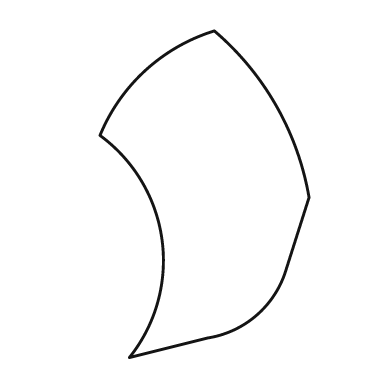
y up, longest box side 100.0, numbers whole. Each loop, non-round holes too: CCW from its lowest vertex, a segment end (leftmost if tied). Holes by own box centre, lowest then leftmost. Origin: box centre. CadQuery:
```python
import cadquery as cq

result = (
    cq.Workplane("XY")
    .moveTo(-23.0, -50.0)
    .lineTo(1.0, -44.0)
    .threePointArc((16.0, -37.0), (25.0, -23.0))
    .lineTo(32.0, -1.0)
    .threePointArc((22.0, 27.0), (3.0, 50.0))
    .threePointArc((-18.0, 38.0), (-32.0, 18.0))
    .threePointArc((-13.0, -14.0), (-23.0, -50.0))
    .close()
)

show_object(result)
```